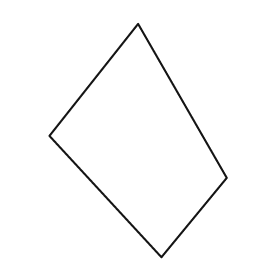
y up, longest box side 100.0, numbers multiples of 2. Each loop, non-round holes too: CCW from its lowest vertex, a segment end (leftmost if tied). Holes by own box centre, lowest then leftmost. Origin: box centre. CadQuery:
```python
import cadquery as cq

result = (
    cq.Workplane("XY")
    .moveTo(10.0, -50.0)
    .lineTo(38.0, -16.0)
    .lineTo(0.0, 50.0)
    .lineTo(-38.0, 2.0)
    .close()
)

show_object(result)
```